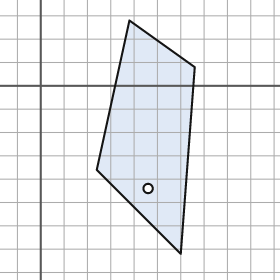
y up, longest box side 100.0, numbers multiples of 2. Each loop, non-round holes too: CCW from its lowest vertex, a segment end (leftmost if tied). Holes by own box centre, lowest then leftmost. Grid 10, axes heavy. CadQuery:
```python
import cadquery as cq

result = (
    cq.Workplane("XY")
    .moveTo(60.0, -72.0)
    .lineTo(66.0, 8.0)
    .lineTo(38.0, 28.0)
    .lineTo(24.0, -36.0)
    .close()
    .moveTo(46.0, -44.0)
    .circle(2.0)
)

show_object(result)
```